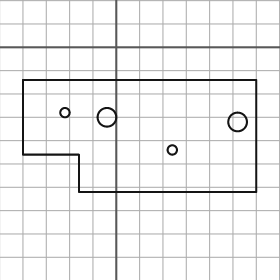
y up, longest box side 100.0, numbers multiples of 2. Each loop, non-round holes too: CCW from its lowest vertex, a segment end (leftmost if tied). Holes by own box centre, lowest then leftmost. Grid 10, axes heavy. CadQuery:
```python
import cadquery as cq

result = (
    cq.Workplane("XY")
    .moveTo(-16.0, -62.0)
    .lineTo(60.0, -62.0)
    .lineTo(60.0, -14.0)
    .lineTo(-40.0, -14.0)
    .lineTo(-40.0, -46.0)
    .lineTo(-16.0, -46.0)
    .close()
    .moveTo(24.0, -44.0)
    .circle(2.0)
    .moveTo(52.0, -32.0)
    .circle(4.0)
    .moveTo(-4.0, -30.0)
    .circle(4.0)
    .moveTo(-22.0, -28.0)
    .circle(2.0)
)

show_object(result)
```